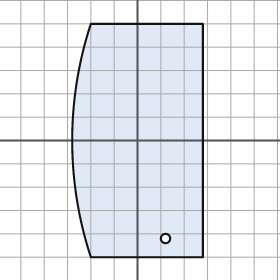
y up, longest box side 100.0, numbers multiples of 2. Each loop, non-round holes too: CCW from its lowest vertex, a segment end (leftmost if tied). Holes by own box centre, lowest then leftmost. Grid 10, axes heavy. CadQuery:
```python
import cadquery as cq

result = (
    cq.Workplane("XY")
    .moveTo(-20.0, -50.0)
    .lineTo(28.0, -50.0)
    .lineTo(28.0, 50.0)
    .lineTo(-20.0, 50.0)
    .threePointArc((-28.0, 0.0), (-20.0, -50.0))
    .close()
    .moveTo(12.0, -42.0)
    .circle(2.0)
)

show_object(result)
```